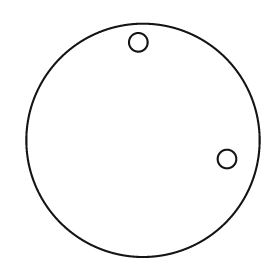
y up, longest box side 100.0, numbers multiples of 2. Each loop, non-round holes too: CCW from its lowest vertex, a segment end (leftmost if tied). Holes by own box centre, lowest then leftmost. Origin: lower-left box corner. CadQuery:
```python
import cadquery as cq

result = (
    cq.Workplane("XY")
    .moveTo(50.0, 50.0)
    .circle(50.0)
    .moveTo(86.0, 42.0)
    .circle(4.0)
    .moveTo(48.0, 92.0)
    .circle(4.0)
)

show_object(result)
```